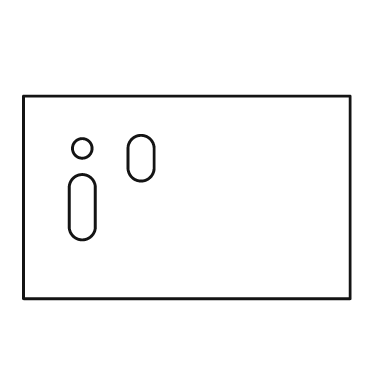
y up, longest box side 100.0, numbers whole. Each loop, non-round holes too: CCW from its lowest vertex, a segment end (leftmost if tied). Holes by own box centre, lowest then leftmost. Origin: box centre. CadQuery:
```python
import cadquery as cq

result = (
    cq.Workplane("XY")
    .moveTo(-50.0, -31.0)
    .lineTo(50.0, -31.0)
    .lineTo(50.0, 31.0)
    .lineTo(-50.0, 31.0)
    .close()
    .moveTo(-36.0, -9.0)
    .threePointArc((-32.0, -13.0), (-28.0, -9.0))
    .lineTo(-28.0, 3.0)
    .threePointArc((-32.0, 7.0), (-36.0, 3.0))
    .close()
    .moveTo(-18.0, 9.0)
    .threePointArc((-14.0, 5.0), (-10.0, 9.0))
    .lineTo(-10.0, 15.0)
    .threePointArc((-14.0, 19.0), (-18.0, 15.0))
    .close()
    .moveTo(-32.0, 15.0)
    .circle(3.0)
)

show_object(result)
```